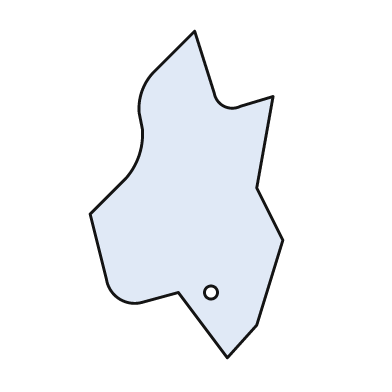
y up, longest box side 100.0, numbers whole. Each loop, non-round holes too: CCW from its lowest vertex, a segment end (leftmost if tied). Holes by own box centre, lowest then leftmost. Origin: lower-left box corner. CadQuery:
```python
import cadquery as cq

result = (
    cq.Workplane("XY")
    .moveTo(42.0, 0.0)
    .lineTo(51.0, 10.0)
    .lineTo(59.0, 36.0)
    .lineTo(51.0, 52.0)
    .lineTo(56.0, 80.0)
    .lineTo(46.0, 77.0)
    .threePointArc((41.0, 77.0), (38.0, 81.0))
    .lineTo(32.0, 100.0)
    .lineTo(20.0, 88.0)
    .threePointArc((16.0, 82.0), (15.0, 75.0))
    .lineTo(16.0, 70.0)
    .threePointArc((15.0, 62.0), (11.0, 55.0))
    .lineTo(0.0, 44.0)
    .lineTo(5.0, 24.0)
    .threePointArc((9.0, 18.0), (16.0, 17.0))
    .lineTo(27.0, 20.0)
    .close()
    .moveTo(37.0, 20.0)
    .circle(2.0)
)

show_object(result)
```